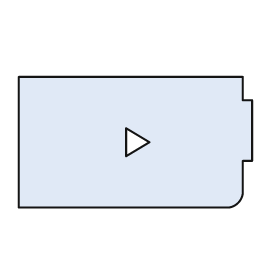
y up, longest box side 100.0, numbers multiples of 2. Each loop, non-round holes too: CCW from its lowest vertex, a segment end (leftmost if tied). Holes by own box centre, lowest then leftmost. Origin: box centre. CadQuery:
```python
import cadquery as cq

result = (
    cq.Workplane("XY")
    .moveTo(-50.0, -28.0)
    .lineTo(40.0, -28.0)
    .threePointArc((44.0, -26.0), (46.0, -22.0))
    .lineTo(46.0, -8.0)
    .lineTo(50.0, -8.0)
    .lineTo(50.0, 18.0)
    .lineTo(46.0, 18.0)
    .lineTo(46.0, 28.0)
    .lineTo(-50.0, 28.0)
    .close()
    .moveTo(-4.0, -6.0)
    .lineTo(6.0, 0.0)
    .lineTo(-4.0, 6.0)
    .close()
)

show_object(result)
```